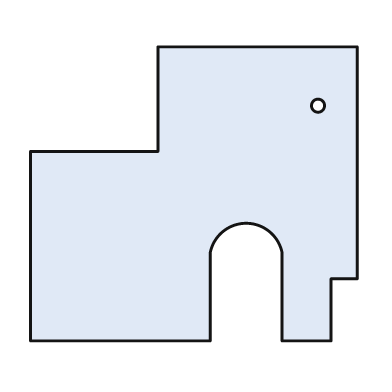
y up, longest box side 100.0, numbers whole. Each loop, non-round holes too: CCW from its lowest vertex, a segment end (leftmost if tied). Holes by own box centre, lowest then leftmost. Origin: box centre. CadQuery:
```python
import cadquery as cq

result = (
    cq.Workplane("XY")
    .moveTo(-50.0, -45.0)
    .lineTo(5.0, -45.0)
    .lineTo(5.0, -18.0)
    .threePointArc((16.0, -9.0), (27.0, -18.0))
    .lineTo(27.0, -45.0)
    .lineTo(42.0, -45.0)
    .lineTo(42.0, -26.0)
    .lineTo(50.0, -26.0)
    .lineTo(50.0, 45.0)
    .lineTo(-11.0, 45.0)
    .lineTo(-11.0, 13.0)
    .lineTo(-50.0, 13.0)
    .close()
    .moveTo(38.0, 27.0)
    .circle(2.0)
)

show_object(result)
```